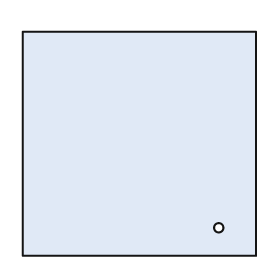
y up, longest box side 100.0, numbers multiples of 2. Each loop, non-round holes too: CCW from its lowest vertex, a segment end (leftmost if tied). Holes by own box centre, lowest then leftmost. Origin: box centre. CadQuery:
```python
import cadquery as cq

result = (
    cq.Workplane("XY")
    .moveTo(-50.0, -48.0)
    .lineTo(50.0, -48.0)
    .lineTo(50.0, 48.0)
    .lineTo(-50.0, 48.0)
    .close()
    .moveTo(34.0, -36.0)
    .circle(2.0)
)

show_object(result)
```